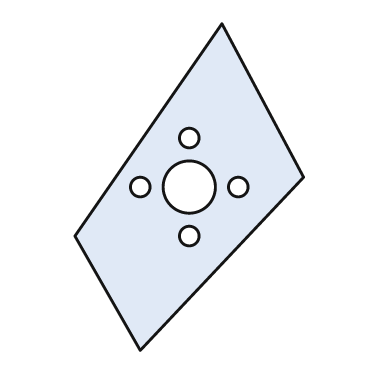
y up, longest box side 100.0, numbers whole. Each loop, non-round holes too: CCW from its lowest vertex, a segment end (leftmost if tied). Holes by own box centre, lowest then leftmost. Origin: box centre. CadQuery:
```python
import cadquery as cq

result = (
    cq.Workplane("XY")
    .moveTo(-15.0, -50.0)
    .lineTo(35.0, 3.0)
    .lineTo(10.0, 50.0)
    .lineTo(-35.0, -15.0)
    .close()
    .moveTo(0.0, -15.0)
    .circle(3.0)
    .moveTo(-15.0, 0.0)
    .circle(3.0)
    .moveTo(0.0, 0.0)
    .circle(8.0)
    .moveTo(15.0, 0.0)
    .circle(3.0)
    .moveTo(0.0, 15.0)
    .circle(3.0)
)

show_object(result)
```